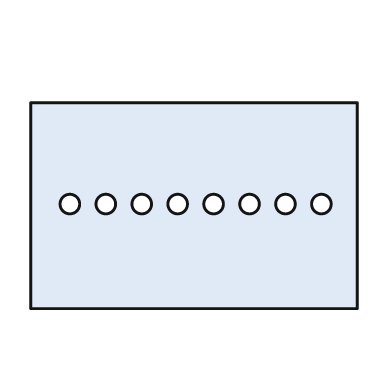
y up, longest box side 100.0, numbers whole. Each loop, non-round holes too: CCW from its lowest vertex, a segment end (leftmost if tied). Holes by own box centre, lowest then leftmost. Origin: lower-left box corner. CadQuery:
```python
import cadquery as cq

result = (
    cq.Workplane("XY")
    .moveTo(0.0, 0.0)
    .lineTo(100.0, 0.0)
    .lineTo(100.0, 63.0)
    .lineTo(0.0, 63.0)
    .close()
    .moveTo(12.0, 32.0)
    .circle(3.0)
    .moveTo(23.0, 32.0)
    .circle(3.0)
    .moveTo(34.0, 32.0)
    .circle(3.0)
    .moveTo(45.0, 32.0)
    .circle(3.0)
    .moveTo(56.0, 32.0)
    .circle(3.0)
    .moveTo(67.0, 32.0)
    .circle(3.0)
    .moveTo(78.0, 32.0)
    .circle(3.0)
    .moveTo(89.0, 32.0)
    .circle(3.0)
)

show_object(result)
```